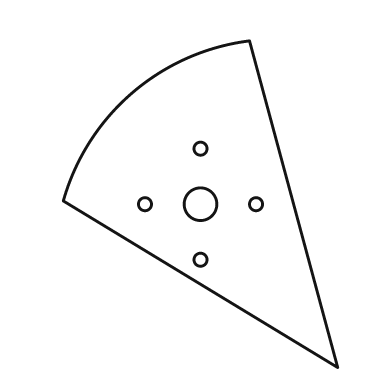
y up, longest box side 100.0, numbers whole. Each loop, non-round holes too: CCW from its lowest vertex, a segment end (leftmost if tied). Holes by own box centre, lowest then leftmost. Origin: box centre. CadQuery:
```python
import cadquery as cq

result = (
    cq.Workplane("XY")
    .moveTo(42.0, -50.0)
    .lineTo(15.0, 50.0)
    .threePointArc((-21.0, 34.0), (-42.0, 1.0))
    .close()
    .moveTo(0.0, -17.0)
    .circle(2.0)
    .moveTo(-17.0, 0.0)
    .circle(2.0)
    .moveTo(0.0, 0.0)
    .circle(5.0)
    .moveTo(17.0, 0.0)
    .circle(2.0)
    .moveTo(0.0, 17.0)
    .circle(2.0)
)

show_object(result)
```